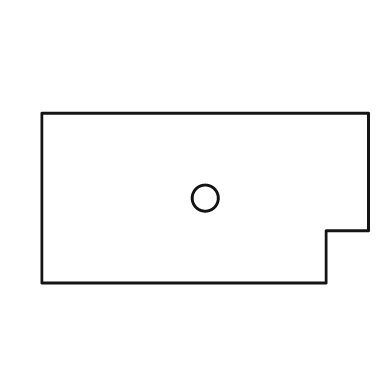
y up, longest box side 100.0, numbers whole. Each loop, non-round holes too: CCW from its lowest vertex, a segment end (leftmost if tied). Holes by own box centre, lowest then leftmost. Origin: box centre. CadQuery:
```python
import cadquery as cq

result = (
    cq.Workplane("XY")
    .moveTo(-50.0, -26.0)
    .lineTo(37.0, -26.0)
    .lineTo(37.0, -10.0)
    .lineTo(50.0, -10.0)
    .lineTo(50.0, 26.0)
    .lineTo(-50.0, 26.0)
    .close()
    .moveTo(0.0, 0.0)
    .circle(4.0)
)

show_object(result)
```